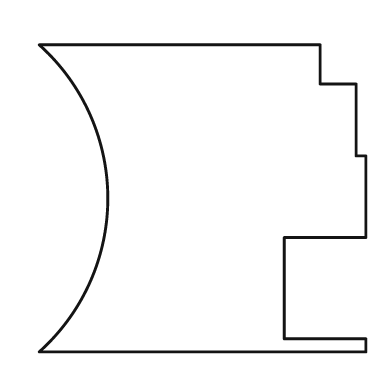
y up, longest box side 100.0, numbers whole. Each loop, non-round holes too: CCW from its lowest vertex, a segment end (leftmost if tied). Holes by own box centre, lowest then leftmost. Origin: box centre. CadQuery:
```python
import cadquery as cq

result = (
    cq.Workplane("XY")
    .moveTo(-50.0, -47.0)
    .lineTo(50.0, -47.0)
    .lineTo(50.0, -43.0)
    .lineTo(25.0, -43.0)
    .lineTo(25.0, -12.0)
    .lineTo(50.0, -12.0)
    .lineTo(50.0, 13.0)
    .lineTo(47.0, 13.0)
    .lineTo(47.0, 35.0)
    .lineTo(36.0, 35.0)
    .lineTo(36.0, 47.0)
    .lineTo(-50.0, 47.0)
    .threePointArc((-29.0, 0.0), (-50.0, -47.0))
    .close()
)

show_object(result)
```